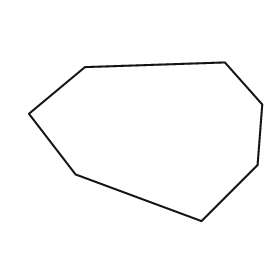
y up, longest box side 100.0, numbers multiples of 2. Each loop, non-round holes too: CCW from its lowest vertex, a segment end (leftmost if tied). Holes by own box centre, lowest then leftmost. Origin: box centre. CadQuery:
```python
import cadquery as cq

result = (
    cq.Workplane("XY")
    .moveTo(24.0, -34.0)
    .lineTo(48.0, -10.0)
    .lineTo(50.0, 16.0)
    .lineTo(34.0, 34.0)
    .lineTo(-26.0, 32.0)
    .lineTo(-50.0, 12.0)
    .lineTo(-30.0, -14.0)
    .close()
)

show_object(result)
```